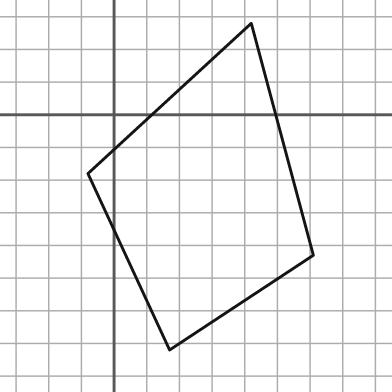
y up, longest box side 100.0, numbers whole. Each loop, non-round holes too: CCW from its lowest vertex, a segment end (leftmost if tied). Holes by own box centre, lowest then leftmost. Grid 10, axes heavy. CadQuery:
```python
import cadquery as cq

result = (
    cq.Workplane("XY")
    .moveTo(17.0, -72.0)
    .lineTo(61.0, -43.0)
    .lineTo(42.0, 28.0)
    .lineTo(-8.0, -18.0)
    .close()
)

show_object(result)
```